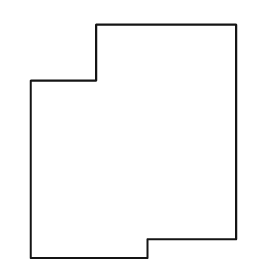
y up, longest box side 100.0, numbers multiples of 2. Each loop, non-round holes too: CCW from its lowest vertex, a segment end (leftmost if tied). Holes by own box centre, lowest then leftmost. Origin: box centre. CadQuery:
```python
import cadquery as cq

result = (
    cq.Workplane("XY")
    .moveTo(-44.0, -50.0)
    .lineTo(6.0, -50.0)
    .lineTo(6.0, -42.0)
    .lineTo(44.0, -42.0)
    .lineTo(44.0, 50.0)
    .lineTo(-16.0, 50.0)
    .lineTo(-16.0, 26.0)
    .lineTo(-44.0, 26.0)
    .close()
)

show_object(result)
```